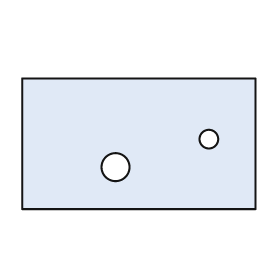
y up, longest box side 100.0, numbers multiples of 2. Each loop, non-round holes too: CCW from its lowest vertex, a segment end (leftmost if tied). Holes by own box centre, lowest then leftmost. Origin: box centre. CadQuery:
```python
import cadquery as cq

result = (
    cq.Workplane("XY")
    .moveTo(-50.0, -28.0)
    .lineTo(50.0, -28.0)
    .lineTo(50.0, 28.0)
    .lineTo(-50.0, 28.0)
    .close()
    .moveTo(-10.0, -10.0)
    .circle(6.0)
    .moveTo(30.0, 2.0)
    .circle(4.0)
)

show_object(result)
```